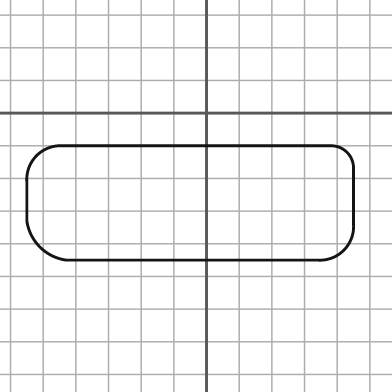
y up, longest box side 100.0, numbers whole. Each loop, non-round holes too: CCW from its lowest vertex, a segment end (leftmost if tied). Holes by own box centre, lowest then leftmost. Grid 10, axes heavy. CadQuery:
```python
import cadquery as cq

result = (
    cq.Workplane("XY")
    .moveTo(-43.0, -45.0)
    .lineTo(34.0, -45.0)
    .threePointArc((42.0, -42.0), (45.0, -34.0))
    .lineTo(45.0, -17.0)
    .threePointArc((43.0, -12.0), (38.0, -10.0))
    .lineTo(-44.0, -10.0)
    .threePointArc((-52.0, -13.0), (-55.0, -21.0))
    .lineTo(-55.0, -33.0)
    .threePointArc((-51.0, -41.0), (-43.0, -45.0))
    .close()
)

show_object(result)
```